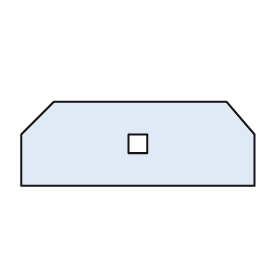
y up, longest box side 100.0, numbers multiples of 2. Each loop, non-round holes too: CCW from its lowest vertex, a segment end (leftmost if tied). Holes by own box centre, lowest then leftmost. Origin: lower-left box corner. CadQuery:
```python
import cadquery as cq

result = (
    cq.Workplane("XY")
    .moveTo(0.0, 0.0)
    .lineTo(100.0, 0.0)
    .lineTo(100.0, 22.0)
    .lineTo(88.0, 36.0)
    .lineTo(14.0, 36.0)
    .lineTo(0.0, 22.0)
    .close()
    .moveTo(46.0, 14.0)
    .lineTo(54.0, 14.0)
    .lineTo(54.0, 22.0)
    .lineTo(46.0, 22.0)
    .close()
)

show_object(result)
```